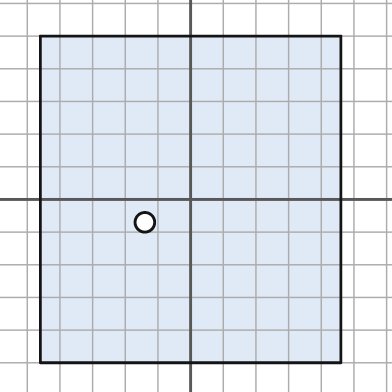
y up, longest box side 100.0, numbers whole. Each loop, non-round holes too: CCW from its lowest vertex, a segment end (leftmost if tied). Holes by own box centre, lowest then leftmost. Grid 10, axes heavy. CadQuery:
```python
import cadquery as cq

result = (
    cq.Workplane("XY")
    .moveTo(-46.0, -50.0)
    .lineTo(46.0, -50.0)
    .lineTo(46.0, 50.0)
    .lineTo(-46.0, 50.0)
    .close()
    .moveTo(-14.0, -7.0)
    .circle(3.0)
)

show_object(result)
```